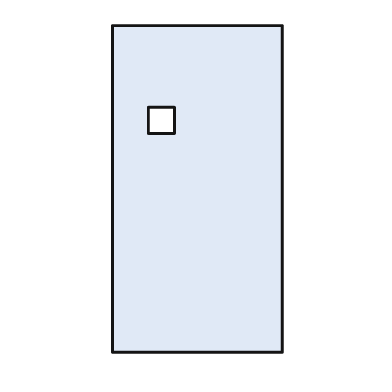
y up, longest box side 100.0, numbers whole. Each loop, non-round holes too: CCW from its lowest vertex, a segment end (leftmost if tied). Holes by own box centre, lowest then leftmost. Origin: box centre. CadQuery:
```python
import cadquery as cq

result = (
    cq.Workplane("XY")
    .moveTo(-26.0, -50.0)
    .lineTo(26.0, -50.0)
    .lineTo(26.0, 50.0)
    .lineTo(-26.0, 50.0)
    .close()
    .moveTo(-15.0, 17.0)
    .lineTo(-7.0, 17.0)
    .lineTo(-7.0, 25.0)
    .lineTo(-15.0, 25.0)
    .close()
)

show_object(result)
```